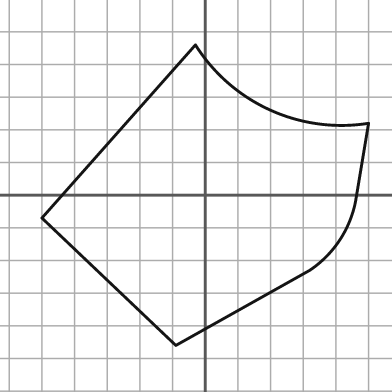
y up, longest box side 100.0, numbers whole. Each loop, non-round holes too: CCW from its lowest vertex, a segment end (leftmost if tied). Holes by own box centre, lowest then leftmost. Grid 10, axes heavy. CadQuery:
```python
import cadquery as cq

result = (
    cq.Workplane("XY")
    .moveTo(-9.0, -46.0)
    .lineTo(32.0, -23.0)
    .threePointArc((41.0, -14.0), (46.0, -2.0))
    .lineTo(50.0, 22.0)
    .threePointArc((20.0, 26.0), (-3.0, 46.0))
    .lineTo(-50.0, -7.0)
    .close()
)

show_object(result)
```